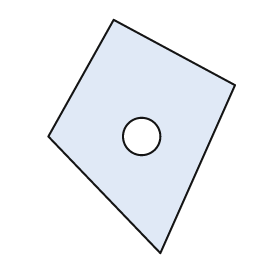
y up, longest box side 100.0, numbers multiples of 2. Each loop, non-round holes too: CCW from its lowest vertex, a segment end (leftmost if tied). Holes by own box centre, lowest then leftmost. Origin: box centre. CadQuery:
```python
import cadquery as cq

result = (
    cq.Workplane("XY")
    .moveTo(8.0, -50.0)
    .lineTo(40.0, 22.0)
    .lineTo(-12.0, 50.0)
    .lineTo(-40.0, 0.0)
    .close()
    .moveTo(0.0, 0.0)
    .circle(8.0)
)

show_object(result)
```